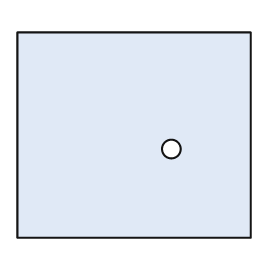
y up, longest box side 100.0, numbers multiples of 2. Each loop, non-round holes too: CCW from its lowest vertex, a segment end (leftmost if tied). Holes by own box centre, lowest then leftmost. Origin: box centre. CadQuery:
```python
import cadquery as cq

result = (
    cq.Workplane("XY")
    .moveTo(-50.0, -44.0)
    .lineTo(50.0, -44.0)
    .lineTo(50.0, 44.0)
    .lineTo(-50.0, 44.0)
    .close()
    .moveTo(16.0, -6.0)
    .circle(4.0)
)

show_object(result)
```